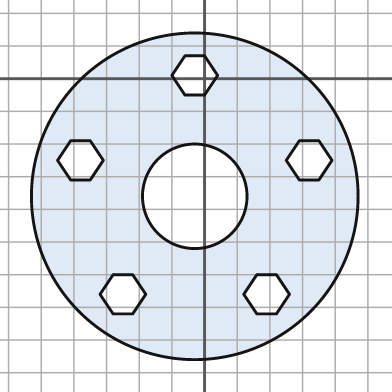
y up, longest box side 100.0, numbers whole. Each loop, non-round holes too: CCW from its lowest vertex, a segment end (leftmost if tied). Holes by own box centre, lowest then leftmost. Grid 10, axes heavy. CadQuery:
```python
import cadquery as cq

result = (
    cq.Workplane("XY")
    .moveTo(-3.0, -36.0)
    .circle(50.0)
    .moveTo(-28.0, -72.0)
    .lineTo(-22.0, -72.0)
    .lineTo(-18.0, -66.0)
    .lineTo(-22.0, -60.0)
    .lineTo(-28.0, -60.0)
    .lineTo(-32.0, -66.0)
    .close()
    .moveTo(16.0, -72.0)
    .lineTo(22.0, -72.0)
    .lineTo(26.0, -66.0)
    .lineTo(22.0, -60.0)
    .lineTo(16.0, -60.0)
    .lineTo(12.0, -66.0)
    .close()
    .moveTo(-3.0, -36.0)
    .circle(16.0)
    .moveTo(-41.0, -31.0)
    .lineTo(-35.0, -31.0)
    .lineTo(-31.0, -25.0)
    .lineTo(-35.0, -19.0)
    .lineTo(-41.0, -19.0)
    .lineTo(-45.0, -25.0)
    .close()
    .moveTo(29.0, -31.0)
    .lineTo(35.0, -31.0)
    .lineTo(39.0, -25.0)
    .lineTo(35.0, -19.0)
    .lineTo(29.0, -19.0)
    .lineTo(25.0, -25.0)
    .close()
    .moveTo(-6.0, -5.0)
    .lineTo(0.0, -5.0)
    .lineTo(4.0, 1.0)
    .lineTo(0.0, 7.0)
    .lineTo(-6.0, 7.0)
    .lineTo(-10.0, 1.0)
    .close()
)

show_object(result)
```